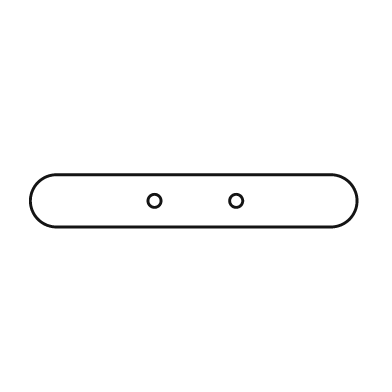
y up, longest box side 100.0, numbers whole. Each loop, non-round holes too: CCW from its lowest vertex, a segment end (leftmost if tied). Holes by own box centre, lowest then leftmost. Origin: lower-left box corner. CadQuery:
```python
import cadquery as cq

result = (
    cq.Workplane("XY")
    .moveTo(8.0, 0.0)
    .lineTo(92.0, 0.0)
    .threePointArc((100.0, 8.0), (92.0, 16.0))
    .lineTo(8.0, 16.0)
    .threePointArc((0.0, 8.0), (8.0, 0.0))
    .close()
    .moveTo(38.0, 8.0)
    .circle(2.0)
    .moveTo(63.0, 8.0)
    .circle(2.0)
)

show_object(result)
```